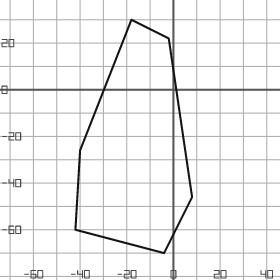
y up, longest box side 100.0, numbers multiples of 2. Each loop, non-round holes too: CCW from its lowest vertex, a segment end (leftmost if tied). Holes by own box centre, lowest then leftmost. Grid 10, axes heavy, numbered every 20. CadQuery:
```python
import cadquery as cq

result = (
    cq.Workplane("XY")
    .moveTo(-4.0, -70.0)
    .lineTo(8.0, -46.0)
    .lineTo(-2.0, 22.0)
    .lineTo(-18.0, 30.0)
    .lineTo(-40.0, -26.0)
    .lineTo(-42.0, -60.0)
    .close()
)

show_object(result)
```